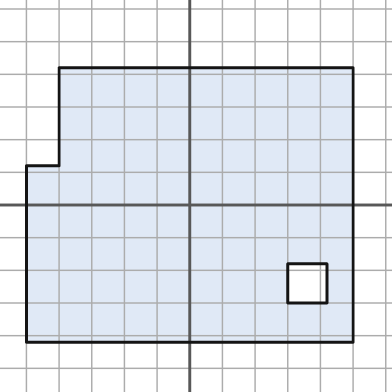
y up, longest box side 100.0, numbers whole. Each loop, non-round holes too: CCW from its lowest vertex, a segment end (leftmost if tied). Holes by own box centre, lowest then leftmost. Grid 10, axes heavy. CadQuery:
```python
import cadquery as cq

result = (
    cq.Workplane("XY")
    .moveTo(-50.0, -42.0)
    .lineTo(50.0, -42.0)
    .lineTo(50.0, 42.0)
    .lineTo(-40.0, 42.0)
    .lineTo(-40.0, 12.0)
    .lineTo(-50.0, 12.0)
    .close()
    .moveTo(30.0, -30.0)
    .lineTo(42.0, -30.0)
    .lineTo(42.0, -18.0)
    .lineTo(30.0, -18.0)
    .close()
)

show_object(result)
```